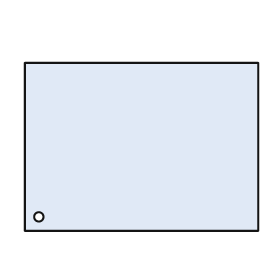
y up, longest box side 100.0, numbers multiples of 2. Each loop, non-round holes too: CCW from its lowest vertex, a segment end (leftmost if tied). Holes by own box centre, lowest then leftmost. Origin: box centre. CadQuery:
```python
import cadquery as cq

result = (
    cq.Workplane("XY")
    .moveTo(-50.0, -36.0)
    .lineTo(50.0, -36.0)
    .lineTo(50.0, 36.0)
    .lineTo(-50.0, 36.0)
    .close()
    .moveTo(-44.0, -30.0)
    .circle(2.0)
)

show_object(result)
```